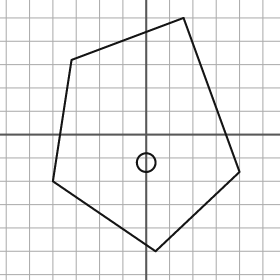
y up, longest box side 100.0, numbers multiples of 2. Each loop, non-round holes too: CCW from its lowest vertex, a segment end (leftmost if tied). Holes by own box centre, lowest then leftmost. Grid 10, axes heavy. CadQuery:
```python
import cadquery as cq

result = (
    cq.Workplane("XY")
    .moveTo(4.0, -50.0)
    .lineTo(40.0, -16.0)
    .lineTo(16.0, 50.0)
    .lineTo(-32.0, 32.0)
    .lineTo(-40.0, -20.0)
    .close()
    .moveTo(0.0, -12.0)
    .circle(4.0)
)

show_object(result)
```